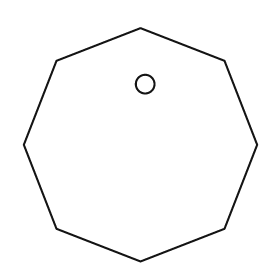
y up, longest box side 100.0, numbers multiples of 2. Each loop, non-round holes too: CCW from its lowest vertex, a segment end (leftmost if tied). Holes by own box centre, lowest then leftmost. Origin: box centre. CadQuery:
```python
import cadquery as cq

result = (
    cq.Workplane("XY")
    .moveTo(0.0, -50.0)
    .lineTo(36.0, -36.0)
    .lineTo(50.0, 0.0)
    .lineTo(36.0, 36.0)
    .lineTo(0.0, 50.0)
    .lineTo(-36.0, 36.0)
    .lineTo(-50.0, 0.0)
    .lineTo(-36.0, -36.0)
    .close()
    .moveTo(2.0, 26.0)
    .circle(4.0)
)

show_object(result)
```